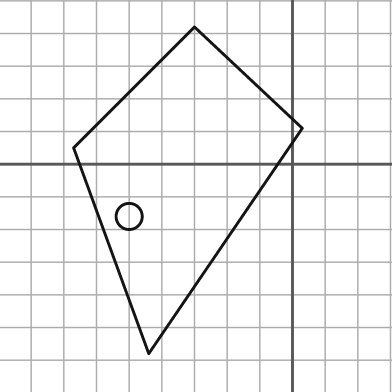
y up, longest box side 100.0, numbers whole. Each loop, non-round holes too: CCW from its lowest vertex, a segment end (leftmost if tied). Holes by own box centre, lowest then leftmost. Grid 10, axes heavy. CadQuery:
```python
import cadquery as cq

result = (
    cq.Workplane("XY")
    .moveTo(-44.0, -58.0)
    .lineTo(3.0, 11.0)
    .lineTo(-30.0, 42.0)
    .lineTo(-67.0, 5.0)
    .close()
    .moveTo(-50.0, -16.0)
    .circle(4.0)
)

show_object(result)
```